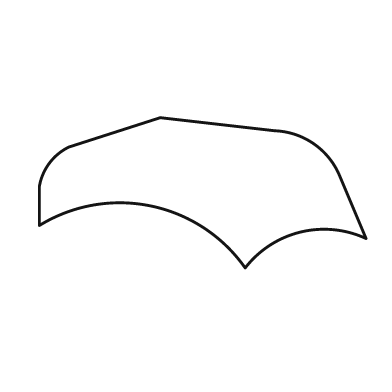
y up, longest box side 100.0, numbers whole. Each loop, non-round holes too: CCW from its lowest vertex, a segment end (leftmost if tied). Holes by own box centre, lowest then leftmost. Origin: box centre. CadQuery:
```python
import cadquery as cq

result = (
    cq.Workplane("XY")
    .moveTo(13.0, -23.0)
    .threePointArc((30.0, -12.0), (50.0, -14.0))
    .lineTo(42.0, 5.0)
    .threePointArc((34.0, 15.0), (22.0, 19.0))
    .lineTo(-13.0, 23.0)
    .lineTo(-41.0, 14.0)
    .threePointArc((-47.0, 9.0), (-50.0, 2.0))
    .lineTo(-50.0, -10.0)
    .threePointArc((-16.0, -4.0), (13.0, -23.0))
    .close()
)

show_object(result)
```